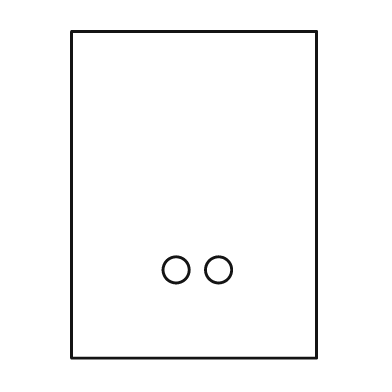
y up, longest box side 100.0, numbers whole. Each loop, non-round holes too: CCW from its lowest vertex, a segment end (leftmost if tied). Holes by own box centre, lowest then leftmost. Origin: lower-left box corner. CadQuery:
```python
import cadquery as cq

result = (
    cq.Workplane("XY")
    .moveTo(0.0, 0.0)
    .lineTo(75.0, 0.0)
    .lineTo(75.0, 100.0)
    .lineTo(0.0, 100.0)
    .close()
    .moveTo(32.0, 27.0)
    .circle(4.0)
    .moveTo(45.0, 27.0)
    .circle(4.0)
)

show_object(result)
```